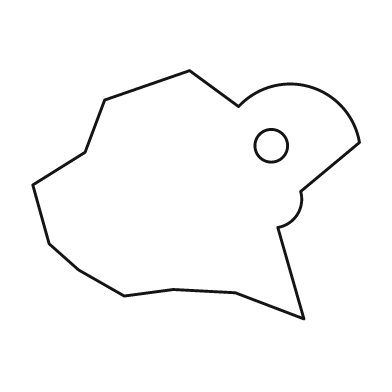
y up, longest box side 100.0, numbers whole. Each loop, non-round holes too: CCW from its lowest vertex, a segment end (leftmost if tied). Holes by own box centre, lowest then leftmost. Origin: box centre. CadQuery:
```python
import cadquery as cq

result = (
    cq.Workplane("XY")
    .moveTo(33.0, -38.0)
    .lineTo(25.0, -10.0)
    .threePointArc((31.0, -6.0), (32.0, 1.0))
    .lineTo(50.0, 16.0)
    .threePointArc((35.0, 33.0), (13.0, 27.0))
    .lineTo(-2.0, 38.0)
    .lineTo(-28.0, 29.0)
    .lineTo(-34.0, 13.0)
    .lineTo(-50.0, 3.0)
    .lineTo(-45.0, -15.0)
    .lineTo(-36.0, -23.0)
    .lineTo(-22.0, -31.0)
    .lineTo(-7.0, -29.0)
    .lineTo(12.0, -30.0)
    .close()
    .moveTo(23.0, 15.0)
    .circle(5.0)
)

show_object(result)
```